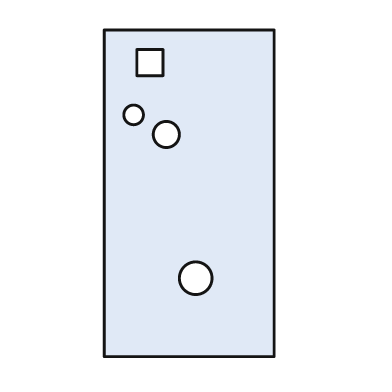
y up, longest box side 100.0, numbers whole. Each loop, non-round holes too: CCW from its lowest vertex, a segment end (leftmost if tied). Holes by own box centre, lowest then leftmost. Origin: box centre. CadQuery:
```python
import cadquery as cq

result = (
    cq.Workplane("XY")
    .moveTo(-26.0, -50.0)
    .lineTo(26.0, -50.0)
    .lineTo(26.0, 50.0)
    .lineTo(-26.0, 50.0)
    .close()
    .moveTo(2.0, -26.0)
    .circle(5.0)
    .moveTo(-7.0, 18.0)
    .circle(4.0)
    .moveTo(-17.0, 24.0)
    .circle(3.0)
    .moveTo(-16.0, 36.0)
    .lineTo(-8.0, 36.0)
    .lineTo(-8.0, 44.0)
    .lineTo(-16.0, 44.0)
    .close()
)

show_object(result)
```